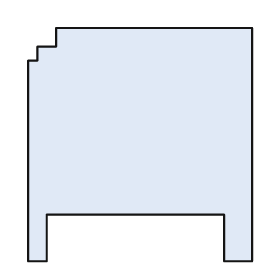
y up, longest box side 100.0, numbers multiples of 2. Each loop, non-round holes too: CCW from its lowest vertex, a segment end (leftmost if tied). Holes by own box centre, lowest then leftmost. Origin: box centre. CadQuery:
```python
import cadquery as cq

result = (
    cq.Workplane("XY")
    .moveTo(-48.0, -50.0)
    .lineTo(-40.0, -50.0)
    .lineTo(-40.0, -30.0)
    .lineTo(36.0, -30.0)
    .lineTo(36.0, -50.0)
    .lineTo(48.0, -50.0)
    .lineTo(48.0, 50.0)
    .lineTo(-36.0, 50.0)
    .lineTo(-36.0, 42.0)
    .lineTo(-44.0, 42.0)
    .lineTo(-44.0, 36.0)
    .lineTo(-48.0, 36.0)
    .close()
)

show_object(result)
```